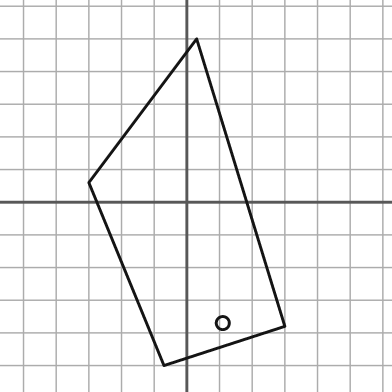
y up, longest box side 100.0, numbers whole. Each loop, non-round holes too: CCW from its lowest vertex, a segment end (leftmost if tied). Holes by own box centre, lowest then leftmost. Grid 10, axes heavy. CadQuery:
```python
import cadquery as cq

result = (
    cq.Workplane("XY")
    .moveTo(-7.0, -50.0)
    .lineTo(30.0, -38.0)
    .lineTo(3.0, 50.0)
    .lineTo(-30.0, 6.0)
    .close()
    .moveTo(11.0, -37.0)
    .circle(2.0)
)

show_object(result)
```